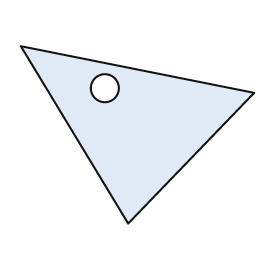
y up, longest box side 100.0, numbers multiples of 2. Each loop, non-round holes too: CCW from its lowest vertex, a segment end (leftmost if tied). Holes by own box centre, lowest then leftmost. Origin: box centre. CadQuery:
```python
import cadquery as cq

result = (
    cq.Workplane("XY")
    .moveTo(-4.0, -38.0)
    .lineTo(50.0, 18.0)
    .lineTo(-50.0, 38.0)
    .close()
    .moveTo(-14.0, 20.0)
    .circle(6.0)
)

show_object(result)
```